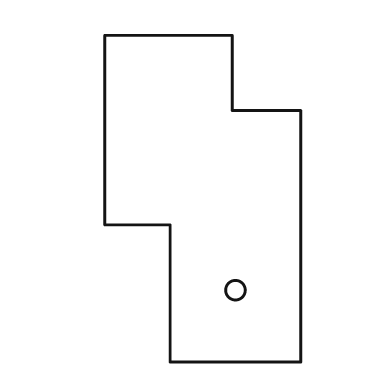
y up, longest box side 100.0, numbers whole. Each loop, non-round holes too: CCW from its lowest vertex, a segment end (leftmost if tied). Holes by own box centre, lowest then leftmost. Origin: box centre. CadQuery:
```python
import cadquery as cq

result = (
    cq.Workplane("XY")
    .moveTo(-10.0, -50.0)
    .lineTo(30.0, -50.0)
    .lineTo(30.0, 27.0)
    .lineTo(9.0, 27.0)
    .lineTo(9.0, 50.0)
    .lineTo(-30.0, 50.0)
    .lineTo(-30.0, -8.0)
    .lineTo(-10.0, -8.0)
    .close()
    .moveTo(10.0, -28.0)
    .circle(3.0)
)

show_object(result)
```